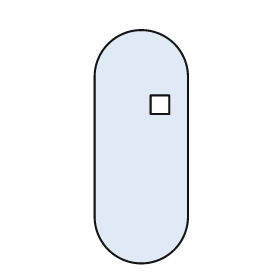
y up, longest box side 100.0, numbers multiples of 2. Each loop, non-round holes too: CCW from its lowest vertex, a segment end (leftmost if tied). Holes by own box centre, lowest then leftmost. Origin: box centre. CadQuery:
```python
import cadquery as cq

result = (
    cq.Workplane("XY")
    .moveTo(-20.0, -30.0)
    .threePointArc((0.0, -50.0), (20.0, -30.0))
    .lineTo(20.0, 30.0)
    .threePointArc((0.0, 50.0), (-20.0, 30.0))
    .close()
    .moveTo(4.0, 14.0)
    .lineTo(12.0, 14.0)
    .lineTo(12.0, 22.0)
    .lineTo(4.0, 22.0)
    .close()
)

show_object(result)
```